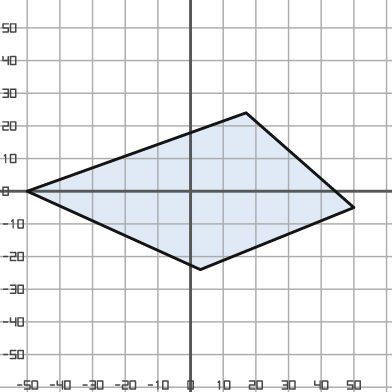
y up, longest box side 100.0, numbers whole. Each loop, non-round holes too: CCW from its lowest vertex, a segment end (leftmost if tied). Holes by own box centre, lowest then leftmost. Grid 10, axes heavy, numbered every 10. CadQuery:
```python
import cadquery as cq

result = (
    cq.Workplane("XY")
    .moveTo(3.0, -24.0)
    .lineTo(50.0, -5.0)
    .lineTo(17.0, 24.0)
    .lineTo(-50.0, 0.0)
    .close()
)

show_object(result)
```